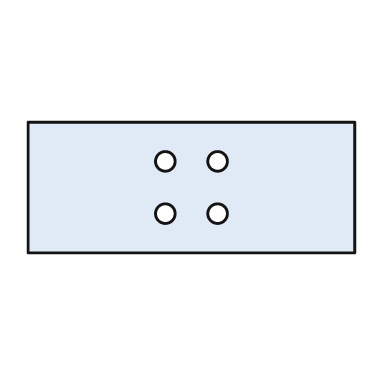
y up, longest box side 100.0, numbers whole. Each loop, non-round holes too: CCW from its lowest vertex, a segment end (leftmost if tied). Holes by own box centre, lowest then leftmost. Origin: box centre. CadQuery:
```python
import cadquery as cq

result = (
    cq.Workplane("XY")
    .moveTo(-50.0, -20.0)
    .lineTo(50.0, -20.0)
    .lineTo(50.0, 20.0)
    .lineTo(-50.0, 20.0)
    .close()
    .moveTo(-8.0, -8.0)
    .circle(3.0)
    .moveTo(8.0, -8.0)
    .circle(3.0)
    .moveTo(-8.0, 8.0)
    .circle(3.0)
    .moveTo(8.0, 8.0)
    .circle(3.0)
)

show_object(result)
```